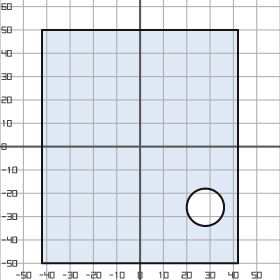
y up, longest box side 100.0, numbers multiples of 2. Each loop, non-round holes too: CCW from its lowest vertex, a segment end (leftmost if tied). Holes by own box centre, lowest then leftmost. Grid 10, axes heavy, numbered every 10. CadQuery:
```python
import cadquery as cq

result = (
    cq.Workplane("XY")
    .moveTo(-42.0, -50.0)
    .lineTo(42.0, -50.0)
    .lineTo(42.0, 50.0)
    .lineTo(-42.0, 50.0)
    .close()
    .moveTo(28.0, -26.0)
    .circle(8.0)
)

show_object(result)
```